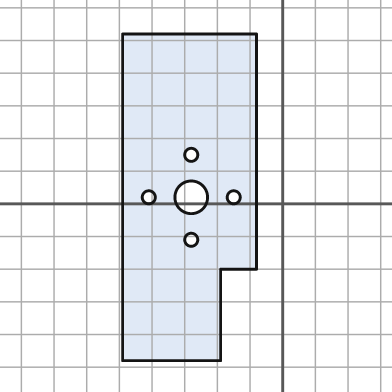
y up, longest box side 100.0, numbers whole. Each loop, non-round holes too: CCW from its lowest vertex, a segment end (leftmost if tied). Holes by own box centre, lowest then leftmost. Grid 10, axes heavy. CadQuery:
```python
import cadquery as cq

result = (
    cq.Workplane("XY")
    .moveTo(-49.0, -48.0)
    .lineTo(-19.0, -48.0)
    .lineTo(-19.0, -20.0)
    .lineTo(-8.0, -20.0)
    .lineTo(-8.0, 52.0)
    .lineTo(-49.0, 52.0)
    .close()
    .moveTo(-28.0, -11.0)
    .circle(2.0)
    .moveTo(-41.0, 2.0)
    .circle(2.0)
    .moveTo(-28.0, 2.0)
    .circle(5.0)
    .moveTo(-15.0, 2.0)
    .circle(2.0)
    .moveTo(-28.0, 15.0)
    .circle(2.0)
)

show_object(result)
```